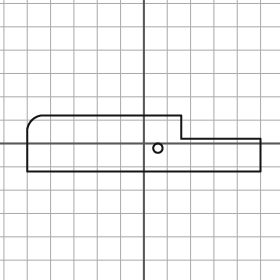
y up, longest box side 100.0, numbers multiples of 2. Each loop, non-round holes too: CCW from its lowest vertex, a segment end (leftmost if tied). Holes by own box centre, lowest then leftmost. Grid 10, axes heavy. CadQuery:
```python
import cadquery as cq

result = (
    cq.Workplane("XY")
    .moveTo(-50.0, -12.0)
    .lineTo(50.0, -12.0)
    .lineTo(50.0, 2.0)
    .lineTo(16.0, 2.0)
    .lineTo(16.0, 12.0)
    .lineTo(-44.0, 12.0)
    .threePointArc((-48.0, 10.0), (-50.0, 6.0))
    .close()
    .moveTo(6.0, -2.0)
    .circle(2.0)
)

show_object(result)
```